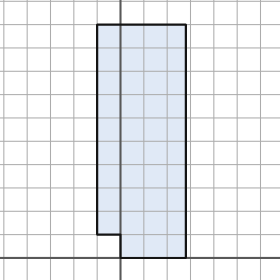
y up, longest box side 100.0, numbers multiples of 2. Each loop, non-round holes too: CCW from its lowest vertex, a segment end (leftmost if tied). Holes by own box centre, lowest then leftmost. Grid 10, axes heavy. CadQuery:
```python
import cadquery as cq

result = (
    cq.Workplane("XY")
    .moveTo(0.0, 0.0)
    .lineTo(28.0, 0.0)
    .lineTo(28.0, 100.0)
    .lineTo(-10.0, 100.0)
    .lineTo(-10.0, 10.0)
    .lineTo(0.0, 10.0)
    .close()
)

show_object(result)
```